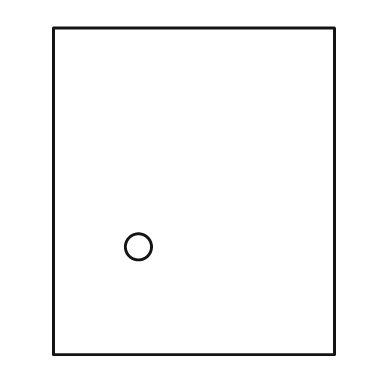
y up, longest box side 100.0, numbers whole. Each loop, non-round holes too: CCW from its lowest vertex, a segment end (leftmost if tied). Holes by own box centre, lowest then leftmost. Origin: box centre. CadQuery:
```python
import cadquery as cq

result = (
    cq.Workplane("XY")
    .moveTo(-43.0, -50.0)
    .lineTo(43.0, -50.0)
    .lineTo(43.0, 50.0)
    .lineTo(-43.0, 50.0)
    .close()
    .moveTo(-17.0, -17.0)
    .circle(4.0)
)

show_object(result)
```